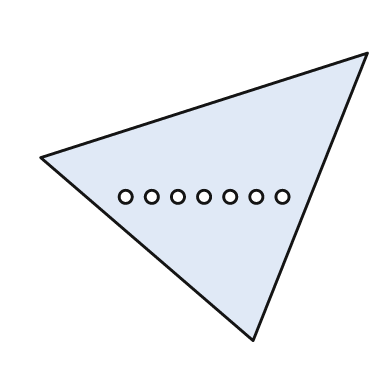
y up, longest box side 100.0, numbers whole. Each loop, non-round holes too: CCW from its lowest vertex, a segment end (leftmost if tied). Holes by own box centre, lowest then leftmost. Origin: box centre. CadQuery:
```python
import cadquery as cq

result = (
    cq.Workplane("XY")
    .moveTo(15.0, -44.0)
    .lineTo(50.0, 44.0)
    .lineTo(-50.0, 12.0)
    .close()
    .moveTo(-24.0, 0.0)
    .circle(2.0)
    .moveTo(-16.0, 0.0)
    .circle(2.0)
    .moveTo(-8.0, 0.0)
    .circle(2.0)
    .moveTo(0.0, 0.0)
    .circle(2.0)
    .moveTo(8.0, 0.0)
    .circle(2.0)
    .moveTo(16.0, 0.0)
    .circle(2.0)
    .moveTo(24.0, 0.0)
    .circle(2.0)
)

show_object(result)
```